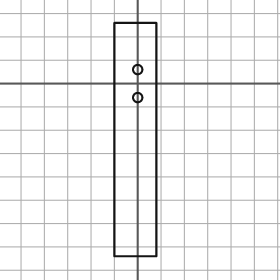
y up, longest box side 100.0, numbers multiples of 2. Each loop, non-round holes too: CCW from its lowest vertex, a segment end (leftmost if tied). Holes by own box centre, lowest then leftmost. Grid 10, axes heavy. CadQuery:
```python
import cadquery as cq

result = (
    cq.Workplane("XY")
    .moveTo(-10.0, -74.0)
    .lineTo(8.0, -74.0)
    .lineTo(8.0, 26.0)
    .lineTo(-10.0, 26.0)
    .close()
    .moveTo(0.0, -6.0)
    .circle(2.0)
    .moveTo(0.0, 6.0)
    .circle(2.0)
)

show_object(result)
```